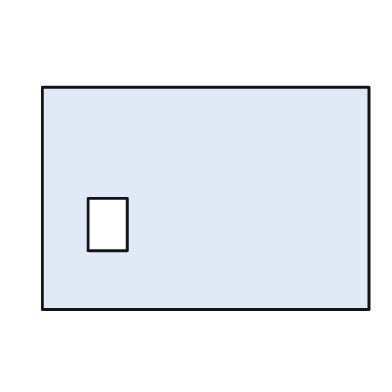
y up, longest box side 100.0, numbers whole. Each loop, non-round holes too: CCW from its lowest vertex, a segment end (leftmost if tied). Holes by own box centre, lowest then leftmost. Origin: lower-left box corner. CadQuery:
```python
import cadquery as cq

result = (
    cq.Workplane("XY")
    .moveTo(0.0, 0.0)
    .lineTo(100.0, 0.0)
    .lineTo(100.0, 68.0)
    .lineTo(0.0, 68.0)
    .close()
    .moveTo(14.0, 18.0)
    .lineTo(26.0, 18.0)
    .lineTo(26.0, 34.0)
    .lineTo(14.0, 34.0)
    .close()
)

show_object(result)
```